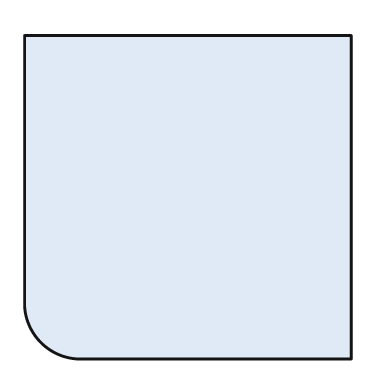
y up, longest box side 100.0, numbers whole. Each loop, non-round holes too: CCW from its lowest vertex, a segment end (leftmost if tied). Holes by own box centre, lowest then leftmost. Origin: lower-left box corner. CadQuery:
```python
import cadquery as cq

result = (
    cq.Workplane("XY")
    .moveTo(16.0, 0.0)
    .lineTo(100.0, 0.0)
    .lineTo(100.0, 99.0)
    .lineTo(0.0, 99.0)
    .lineTo(0.0, 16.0)
    .threePointArc((5.0, 5.0), (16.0, 0.0))
    .close()
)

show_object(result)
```